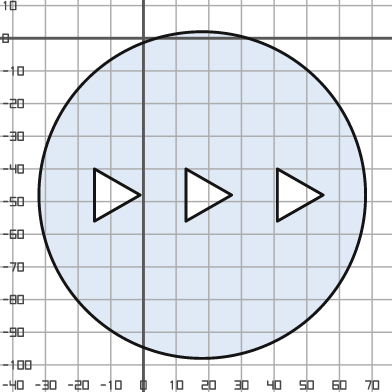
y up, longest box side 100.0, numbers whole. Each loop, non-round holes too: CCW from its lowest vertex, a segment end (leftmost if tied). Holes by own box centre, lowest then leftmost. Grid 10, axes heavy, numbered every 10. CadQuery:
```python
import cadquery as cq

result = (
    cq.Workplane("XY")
    .moveTo(18.0, -48.0)
    .circle(50.0)
    .moveTo(-15.0, -56.0)
    .lineTo(-1.0, -48.0)
    .lineTo(-15.0, -40.0)
    .close()
    .moveTo(13.0, -56.0)
    .lineTo(27.0, -48.0)
    .lineTo(13.0, -40.0)
    .close()
    .moveTo(41.0, -56.0)
    .lineTo(55.0, -48.0)
    .lineTo(41.0, -40.0)
    .close()
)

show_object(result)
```